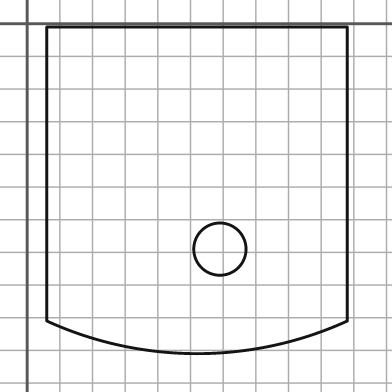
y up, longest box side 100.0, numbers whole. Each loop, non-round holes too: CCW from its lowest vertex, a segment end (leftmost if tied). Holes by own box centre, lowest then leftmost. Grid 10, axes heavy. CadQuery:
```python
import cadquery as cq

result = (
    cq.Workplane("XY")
    .moveTo(6.0, -91.0)
    .threePointArc((52.0, -101.0), (98.0, -91.0))
    .lineTo(98.0, -1.0)
    .lineTo(6.0, -1.0)
    .close()
    .moveTo(59.0, -69.0)
    .circle(8.0)
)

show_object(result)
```